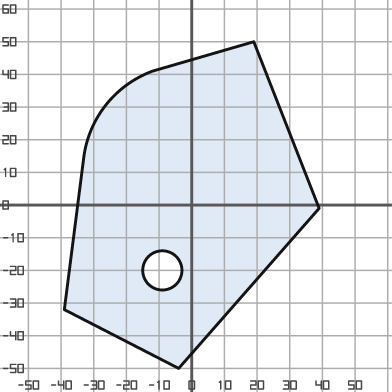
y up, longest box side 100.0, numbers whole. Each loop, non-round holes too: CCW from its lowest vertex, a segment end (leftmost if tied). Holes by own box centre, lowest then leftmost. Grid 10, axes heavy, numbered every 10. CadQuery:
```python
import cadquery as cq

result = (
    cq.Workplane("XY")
    .moveTo(-4.0, -50.0)
    .lineTo(39.0, -1.0)
    .lineTo(19.0, 50.0)
    .lineTo(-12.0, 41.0)
    .threePointArc((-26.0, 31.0), (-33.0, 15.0))
    .lineTo(-39.0, -32.0)
    .close()
    .moveTo(-9.0, -20.0)
    .circle(6.0)
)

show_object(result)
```